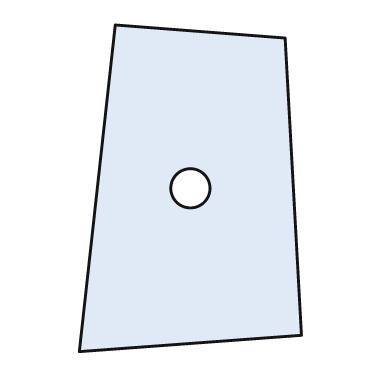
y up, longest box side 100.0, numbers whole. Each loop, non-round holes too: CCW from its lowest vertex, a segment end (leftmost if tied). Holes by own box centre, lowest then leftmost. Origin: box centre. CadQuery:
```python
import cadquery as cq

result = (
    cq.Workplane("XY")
    .moveTo(-34.0, -50.0)
    .lineTo(34.0, -45.0)
    .lineTo(29.0, 46.0)
    .lineTo(-23.0, 50.0)
    .close()
    .moveTo(0.0, 0.0)
    .circle(6.0)
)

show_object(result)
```